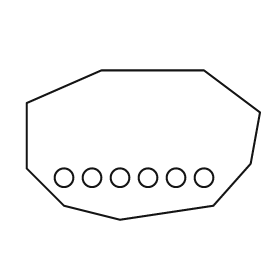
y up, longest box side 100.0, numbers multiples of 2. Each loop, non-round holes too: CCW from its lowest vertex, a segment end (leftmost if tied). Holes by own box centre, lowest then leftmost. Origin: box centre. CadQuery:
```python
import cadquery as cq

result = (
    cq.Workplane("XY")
    .moveTo(-10.0, -32.0)
    .lineTo(30.0, -26.0)
    .lineTo(46.0, -8.0)
    .lineTo(50.0, 14.0)
    .lineTo(26.0, 32.0)
    .lineTo(-18.0, 32.0)
    .lineTo(-50.0, 18.0)
    .lineTo(-50.0, -10.0)
    .lineTo(-34.0, -26.0)
    .close()
    .moveTo(-34.0, -14.0)
    .circle(4.0)
    .moveTo(-22.0, -14.0)
    .circle(4.0)
    .moveTo(-10.0, -14.0)
    .circle(4.0)
    .moveTo(2.0, -14.0)
    .circle(4.0)
    .moveTo(14.0, -14.0)
    .circle(4.0)
    .moveTo(26.0, -14.0)
    .circle(4.0)
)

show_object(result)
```